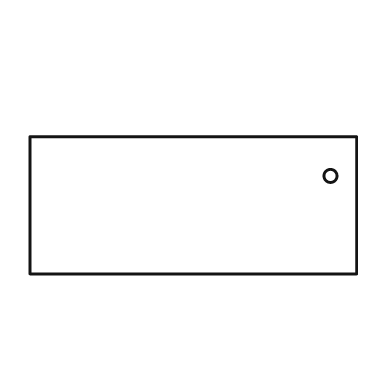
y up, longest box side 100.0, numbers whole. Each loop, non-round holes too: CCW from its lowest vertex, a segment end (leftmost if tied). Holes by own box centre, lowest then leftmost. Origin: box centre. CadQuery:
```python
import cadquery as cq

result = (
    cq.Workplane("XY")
    .moveTo(-50.0, -21.0)
    .lineTo(50.0, -21.0)
    .lineTo(50.0, 21.0)
    .lineTo(-50.0, 21.0)
    .close()
    .moveTo(42.0, 9.0)
    .circle(2.0)
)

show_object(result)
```